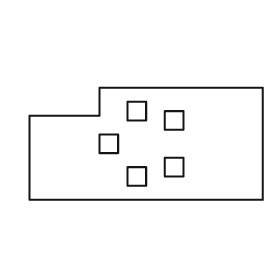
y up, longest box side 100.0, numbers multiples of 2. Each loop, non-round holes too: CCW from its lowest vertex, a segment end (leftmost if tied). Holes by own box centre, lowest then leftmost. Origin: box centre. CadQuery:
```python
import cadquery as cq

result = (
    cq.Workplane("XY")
    .moveTo(-50.0, -24.0)
    .lineTo(50.0, -24.0)
    .lineTo(50.0, 24.0)
    .lineTo(-20.0, 24.0)
    .lineTo(-20.0, 12.0)
    .lineTo(-50.0, 12.0)
    .close()
    .moveTo(-8.0, -18.0)
    .lineTo(0.0, -18.0)
    .lineTo(0.0, -10.0)
    .lineTo(-8.0, -10.0)
    .close()
    .moveTo(8.0, -14.0)
    .lineTo(16.0, -14.0)
    .lineTo(16.0, -6.0)
    .lineTo(8.0, -6.0)
    .close()
    .moveTo(-20.0, -4.0)
    .lineTo(-12.0, -4.0)
    .lineTo(-12.0, 4.0)
    .lineTo(-20.0, 4.0)
    .close()
    .moveTo(8.0, 6.0)
    .lineTo(16.0, 6.0)
    .lineTo(16.0, 14.0)
    .lineTo(8.0, 14.0)
    .close()
    .moveTo(-8.0, 10.0)
    .lineTo(0.0, 10.0)
    .lineTo(0.0, 18.0)
    .lineTo(-8.0, 18.0)
    .close()
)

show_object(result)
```